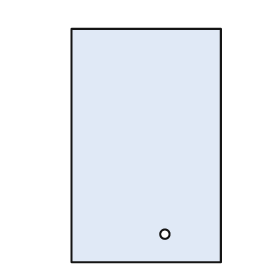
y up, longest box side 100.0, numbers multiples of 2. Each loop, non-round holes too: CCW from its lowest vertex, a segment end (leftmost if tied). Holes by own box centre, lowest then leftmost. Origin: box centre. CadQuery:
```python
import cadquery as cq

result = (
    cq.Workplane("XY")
    .moveTo(-32.0, -50.0)
    .lineTo(32.0, -50.0)
    .lineTo(32.0, 50.0)
    .lineTo(-32.0, 50.0)
    .close()
    .moveTo(8.0, -38.0)
    .circle(2.0)
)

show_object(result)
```